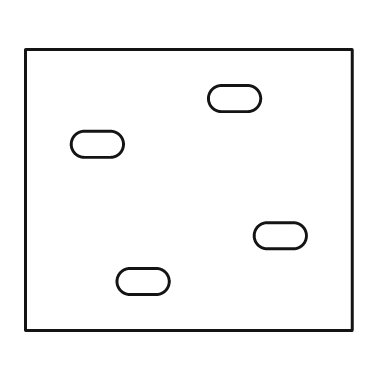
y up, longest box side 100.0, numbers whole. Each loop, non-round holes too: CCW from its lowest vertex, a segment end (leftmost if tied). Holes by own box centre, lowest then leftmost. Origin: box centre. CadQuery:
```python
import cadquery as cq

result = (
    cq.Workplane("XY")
    .moveTo(-50.0, -43.0)
    .lineTo(50.0, -43.0)
    .lineTo(50.0, 43.0)
    .lineTo(-50.0, 43.0)
    .close()
    .moveTo(-18.0, -32.0)
    .lineTo(-10.0, -32.0)
    .threePointArc((-6.0, -28.0), (-10.0, -24.0))
    .lineTo(-18.0, -24.0)
    .threePointArc((-22.0, -28.0), (-18.0, -32.0))
    .close()
    .moveTo(24.0, -18.0)
    .lineTo(32.0, -18.0)
    .threePointArc((36.0, -14.0), (32.0, -10.0))
    .lineTo(24.0, -10.0)
    .threePointArc((20.0, -14.0), (24.0, -18.0))
    .close()
    .moveTo(-32.0, 10.0)
    .lineTo(-24.0, 10.0)
    .threePointArc((-20.0, 14.0), (-24.0, 18.0))
    .lineTo(-32.0, 18.0)
    .threePointArc((-36.0, 14.0), (-32.0, 10.0))
    .close()
    .moveTo(10.0, 24.0)
    .lineTo(18.0, 24.0)
    .threePointArc((22.0, 28.0), (18.0, 32.0))
    .lineTo(10.0, 32.0)
    .threePointArc((6.0, 28.0), (10.0, 24.0))
    .close()
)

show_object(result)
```